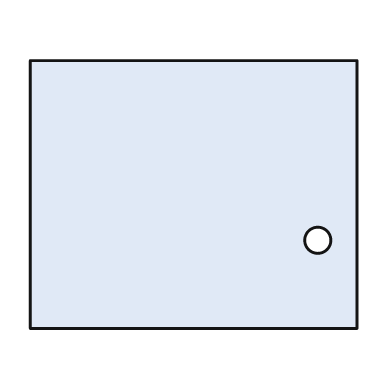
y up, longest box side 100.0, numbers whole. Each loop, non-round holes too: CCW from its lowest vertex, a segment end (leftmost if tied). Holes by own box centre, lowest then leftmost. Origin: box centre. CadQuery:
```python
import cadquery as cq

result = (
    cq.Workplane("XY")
    .moveTo(-50.0, -41.0)
    .lineTo(50.0, -41.0)
    .lineTo(50.0, 41.0)
    .lineTo(-50.0, 41.0)
    .close()
    .moveTo(38.0, -14.0)
    .circle(4.0)
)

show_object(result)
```